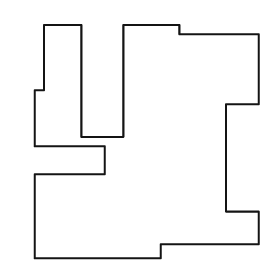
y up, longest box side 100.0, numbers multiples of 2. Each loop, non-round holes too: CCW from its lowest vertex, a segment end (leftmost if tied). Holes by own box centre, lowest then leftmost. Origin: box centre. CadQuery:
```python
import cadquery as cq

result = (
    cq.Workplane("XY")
    .moveTo(-48.0, -50.0)
    .lineTo(6.0, -50.0)
    .lineTo(6.0, -44.0)
    .lineTo(48.0, -44.0)
    .lineTo(48.0, -30.0)
    .lineTo(34.0, -30.0)
    .lineTo(34.0, 16.0)
    .lineTo(48.0, 16.0)
    .lineTo(48.0, 46.0)
    .lineTo(14.0, 46.0)
    .lineTo(14.0, 50.0)
    .lineTo(-10.0, 50.0)
    .lineTo(-10.0, 2.0)
    .lineTo(-28.0, 2.0)
    .lineTo(-28.0, 50.0)
    .lineTo(-44.0, 50.0)
    .lineTo(-44.0, 22.0)
    .lineTo(-48.0, 22.0)
    .lineTo(-48.0, -2.0)
    .lineTo(-18.0, -2.0)
    .lineTo(-18.0, -14.0)
    .lineTo(-48.0, -14.0)
    .close()
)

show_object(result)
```